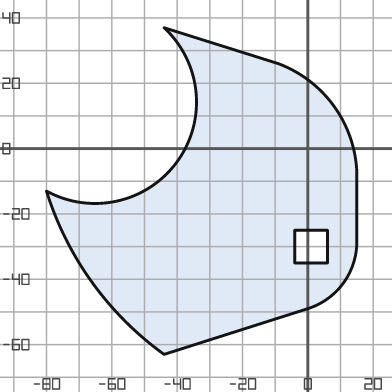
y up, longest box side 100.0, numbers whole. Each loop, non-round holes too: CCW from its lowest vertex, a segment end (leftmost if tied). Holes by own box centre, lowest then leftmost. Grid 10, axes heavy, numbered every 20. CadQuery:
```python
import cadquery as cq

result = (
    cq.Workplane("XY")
    .moveTo(-44.0, -63.0)
    .lineTo(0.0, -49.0)
    .threePointArc((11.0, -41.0), (15.0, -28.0))
    .lineTo(15.0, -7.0)
    .threePointArc((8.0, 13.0), (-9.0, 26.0))
    .lineTo(-44.0, 37.0)
    .threePointArc((-40.0, -4.0), (-80.0, -13.0))
    .threePointArc((-66.0, -41.0), (-44.0, -63.0))
    .close()
    .moveTo(-4.0, -35.0)
    .lineTo(6.0, -35.0)
    .lineTo(6.0, -25.0)
    .lineTo(-4.0, -25.0)
    .close()
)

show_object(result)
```